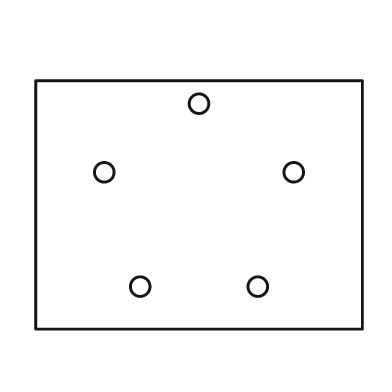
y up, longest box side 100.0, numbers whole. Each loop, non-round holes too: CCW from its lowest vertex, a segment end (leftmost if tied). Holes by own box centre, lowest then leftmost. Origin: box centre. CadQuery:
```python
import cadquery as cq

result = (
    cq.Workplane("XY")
    .moveTo(-50.0, -38.0)
    .lineTo(50.0, -38.0)
    .lineTo(50.0, 38.0)
    .lineTo(-50.0, 38.0)
    .close()
    .moveTo(-18.0, -25.0)
    .circle(3.0)
    .moveTo(18.0, -25.0)
    .circle(3.0)
    .moveTo(-29.0, 10.0)
    .circle(3.0)
    .moveTo(29.0, 10.0)
    .circle(3.0)
    .moveTo(0.0, 31.0)
    .circle(3.0)
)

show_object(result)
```